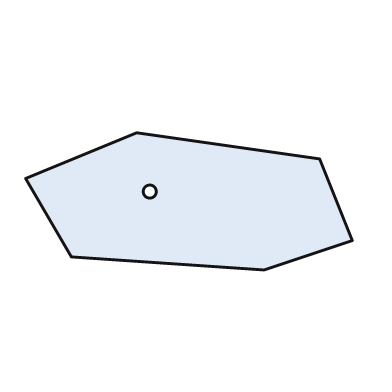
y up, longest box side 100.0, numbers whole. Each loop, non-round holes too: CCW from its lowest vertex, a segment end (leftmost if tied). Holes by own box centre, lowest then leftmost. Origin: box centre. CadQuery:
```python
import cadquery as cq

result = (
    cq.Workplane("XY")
    .moveTo(23.0, -21.0)
    .lineTo(50.0, -12.0)
    .lineTo(40.0, 13.0)
    .lineTo(-16.0, 21.0)
    .lineTo(-50.0, 7.0)
    .lineTo(-36.0, -17.0)
    .close()
    .moveTo(-12.0, 3.0)
    .circle(2.0)
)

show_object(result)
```